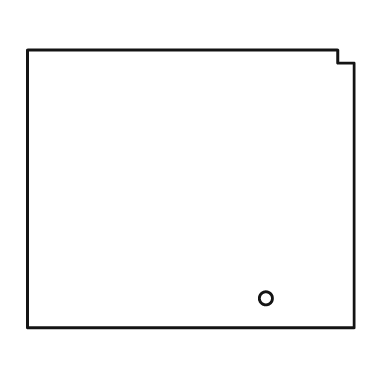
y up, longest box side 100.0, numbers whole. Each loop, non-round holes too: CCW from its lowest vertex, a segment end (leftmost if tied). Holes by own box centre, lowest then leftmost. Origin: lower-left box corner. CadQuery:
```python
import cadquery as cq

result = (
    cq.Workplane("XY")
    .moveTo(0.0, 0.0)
    .lineTo(100.0, 0.0)
    .lineTo(100.0, 81.0)
    .lineTo(95.0, 81.0)
    .lineTo(95.0, 85.0)
    .lineTo(0.0, 85.0)
    .close()
    .moveTo(73.0, 9.0)
    .circle(2.0)
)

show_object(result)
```